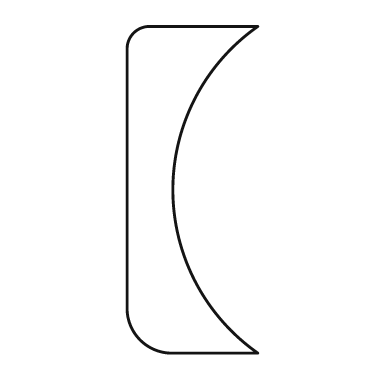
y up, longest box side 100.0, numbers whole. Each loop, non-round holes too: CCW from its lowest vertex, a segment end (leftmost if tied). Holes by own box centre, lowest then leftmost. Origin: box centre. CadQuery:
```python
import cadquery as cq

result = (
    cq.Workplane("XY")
    .moveTo(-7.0, -50.0)
    .lineTo(20.0, -50.0)
    .threePointArc((-6.0, 0.0), (20.0, 50.0))
    .lineTo(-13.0, 50.0)
    .threePointArc((-18.0, 48.0), (-20.0, 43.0))
    .lineTo(-20.0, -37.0)
    .threePointArc((-16.0, -46.0), (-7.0, -50.0))
    .close()
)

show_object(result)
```